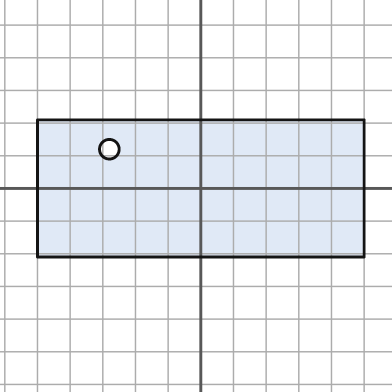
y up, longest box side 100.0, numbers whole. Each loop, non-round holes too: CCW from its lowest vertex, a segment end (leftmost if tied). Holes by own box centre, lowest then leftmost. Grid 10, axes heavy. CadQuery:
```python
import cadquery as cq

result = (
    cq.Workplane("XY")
    .moveTo(-50.0, -21.0)
    .lineTo(50.0, -21.0)
    .lineTo(50.0, 21.0)
    .lineTo(-50.0, 21.0)
    .close()
    .moveTo(-28.0, 12.0)
    .circle(3.0)
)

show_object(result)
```